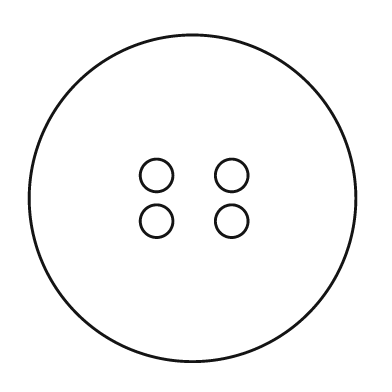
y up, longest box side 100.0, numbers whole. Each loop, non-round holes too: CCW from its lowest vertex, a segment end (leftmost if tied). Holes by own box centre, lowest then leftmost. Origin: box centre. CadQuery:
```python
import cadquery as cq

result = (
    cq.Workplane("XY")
    .moveTo(0.0, 0.0)
    .circle(50.0)
    .moveTo(-11.0, -7.0)
    .circle(5.0)
    .moveTo(12.0, -7.0)
    .circle(5.0)
    .moveTo(-11.0, 7.0)
    .circle(5.0)
    .moveTo(12.0, 7.0)
    .circle(5.0)
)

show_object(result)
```